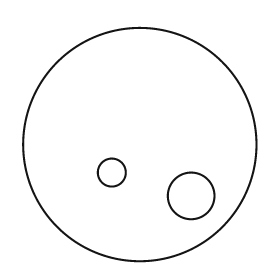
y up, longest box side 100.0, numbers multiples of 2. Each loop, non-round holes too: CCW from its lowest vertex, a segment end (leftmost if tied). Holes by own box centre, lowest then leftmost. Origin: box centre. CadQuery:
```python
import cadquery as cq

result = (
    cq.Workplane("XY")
    .moveTo(0.0, 0.0)
    .circle(50.0)
    .moveTo(22.0, -22.0)
    .circle(10.0)
    .moveTo(-12.0, -12.0)
    .circle(6.0)
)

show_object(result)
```